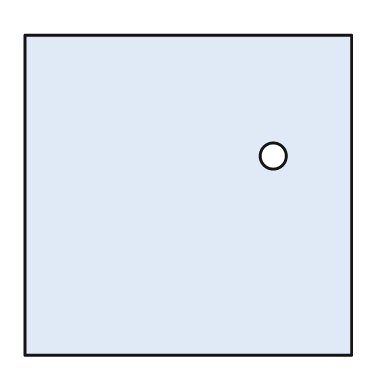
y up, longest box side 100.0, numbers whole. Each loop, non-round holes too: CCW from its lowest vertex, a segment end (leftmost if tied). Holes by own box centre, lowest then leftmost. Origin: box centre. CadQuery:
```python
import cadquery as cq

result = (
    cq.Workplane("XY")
    .moveTo(-50.0, -49.0)
    .lineTo(50.0, -49.0)
    .lineTo(50.0, 49.0)
    .lineTo(-50.0, 49.0)
    .close()
    .moveTo(26.0, 12.0)
    .circle(4.0)
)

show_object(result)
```